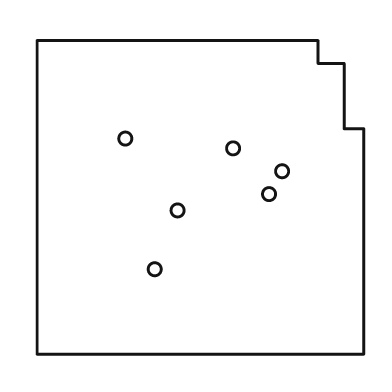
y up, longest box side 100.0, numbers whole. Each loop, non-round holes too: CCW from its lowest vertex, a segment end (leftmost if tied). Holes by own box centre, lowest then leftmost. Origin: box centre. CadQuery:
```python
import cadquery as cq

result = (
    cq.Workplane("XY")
    .moveTo(-50.0, -48.0)
    .lineTo(50.0, -48.0)
    .lineTo(50.0, 21.0)
    .lineTo(44.0, 21.0)
    .lineTo(44.0, 41.0)
    .lineTo(36.0, 41.0)
    .lineTo(36.0, 48.0)
    .lineTo(-50.0, 48.0)
    .close()
    .moveTo(-14.0, -22.0)
    .circle(2.0)
    .moveTo(-7.0, -4.0)
    .circle(2.0)
    .moveTo(21.0, 1.0)
    .circle(2.0)
    .moveTo(25.0, 8.0)
    .circle(2.0)
    .moveTo(10.0, 15.0)
    .circle(2.0)
    .moveTo(-23.0, 18.0)
    .circle(2.0)
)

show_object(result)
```